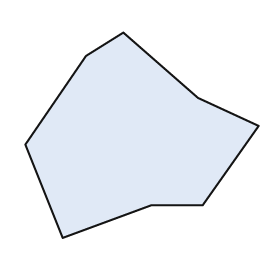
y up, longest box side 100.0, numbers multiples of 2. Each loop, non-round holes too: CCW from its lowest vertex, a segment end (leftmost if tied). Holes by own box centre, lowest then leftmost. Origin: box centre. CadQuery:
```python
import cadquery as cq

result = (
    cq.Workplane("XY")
    .moveTo(-34.0, -44.0)
    .lineTo(4.0, -30.0)
    .lineTo(26.0, -30.0)
    .lineTo(50.0, 4.0)
    .lineTo(24.0, 16.0)
    .lineTo(-8.0, 44.0)
    .lineTo(-24.0, 34.0)
    .lineTo(-50.0, -4.0)
    .close()
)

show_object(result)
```